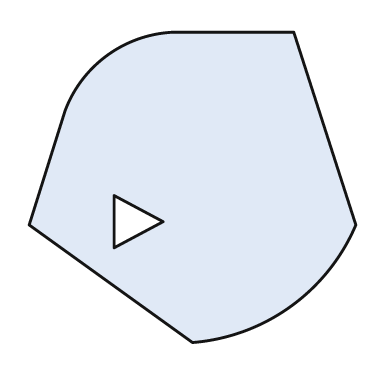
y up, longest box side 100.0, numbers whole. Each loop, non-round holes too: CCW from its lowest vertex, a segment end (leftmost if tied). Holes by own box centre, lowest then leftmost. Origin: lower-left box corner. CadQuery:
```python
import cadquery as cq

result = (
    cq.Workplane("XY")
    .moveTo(50.0, 0.0)
    .threePointArc((80.0, 11.0), (100.0, 36.0))
    .lineTo(81.0, 95.0)
    .lineTo(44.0, 95.0)
    .threePointArc((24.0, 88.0), (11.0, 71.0))
    .lineTo(0.0, 36.0)
    .close()
    .moveTo(26.0, 29.0)
    .lineTo(41.0, 37.0)
    .lineTo(26.0, 45.0)
    .close()
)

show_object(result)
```